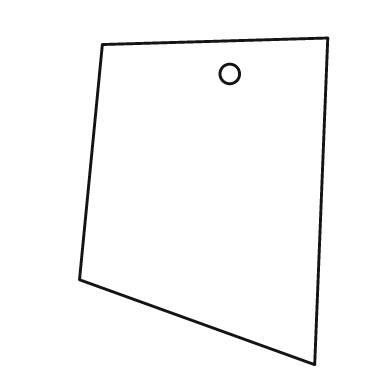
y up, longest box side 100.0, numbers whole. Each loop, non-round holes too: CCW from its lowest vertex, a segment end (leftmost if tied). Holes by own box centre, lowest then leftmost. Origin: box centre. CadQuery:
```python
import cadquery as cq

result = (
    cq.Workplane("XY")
    .moveTo(34.0, -50.0)
    .lineTo(38.0, 50.0)
    .lineTo(-31.0, 48.0)
    .lineTo(-38.0, -24.0)
    .close()
    .moveTo(8.0, 39.0)
    .circle(3.0)
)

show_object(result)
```